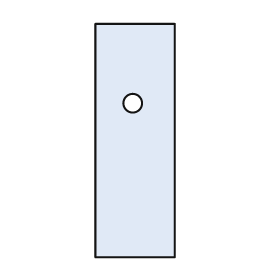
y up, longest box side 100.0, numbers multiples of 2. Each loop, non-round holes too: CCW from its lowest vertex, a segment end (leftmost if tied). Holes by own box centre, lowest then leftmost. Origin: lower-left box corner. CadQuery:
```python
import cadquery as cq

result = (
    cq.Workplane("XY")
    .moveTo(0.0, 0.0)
    .lineTo(34.0, 0.0)
    .lineTo(34.0, 100.0)
    .lineTo(0.0, 100.0)
    .close()
    .moveTo(16.0, 66.0)
    .circle(4.0)
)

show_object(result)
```